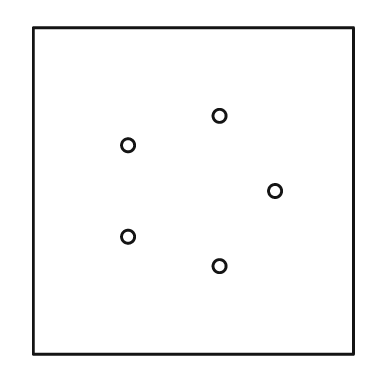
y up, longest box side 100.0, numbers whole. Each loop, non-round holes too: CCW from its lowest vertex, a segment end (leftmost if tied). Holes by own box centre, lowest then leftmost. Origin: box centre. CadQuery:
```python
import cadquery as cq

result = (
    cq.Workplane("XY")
    .moveTo(-49.0, -50.0)
    .lineTo(49.0, -50.0)
    .lineTo(49.0, 50.0)
    .lineTo(-49.0, 50.0)
    .close()
    .moveTo(8.0, -23.0)
    .circle(2.0)
    .moveTo(-20.0, -14.0)
    .circle(2.0)
    .moveTo(25.0, 0.0)
    .circle(2.0)
    .moveTo(-20.0, 14.0)
    .circle(2.0)
    .moveTo(8.0, 23.0)
    .circle(2.0)
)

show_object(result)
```